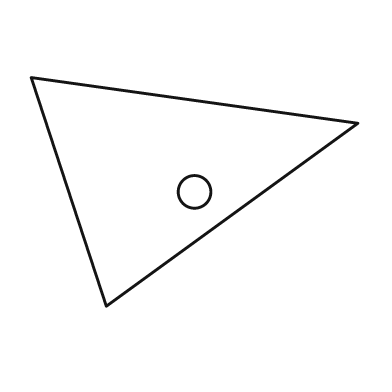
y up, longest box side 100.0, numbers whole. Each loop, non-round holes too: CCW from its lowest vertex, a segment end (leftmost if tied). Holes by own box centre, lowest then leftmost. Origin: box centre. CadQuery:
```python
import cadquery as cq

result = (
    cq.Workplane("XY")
    .moveTo(-27.0, -35.0)
    .lineTo(50.0, 21.0)
    .lineTo(-50.0, 35.0)
    .close()
    .moveTo(0.0, 0.0)
    .circle(5.0)
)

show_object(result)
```